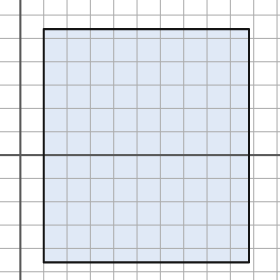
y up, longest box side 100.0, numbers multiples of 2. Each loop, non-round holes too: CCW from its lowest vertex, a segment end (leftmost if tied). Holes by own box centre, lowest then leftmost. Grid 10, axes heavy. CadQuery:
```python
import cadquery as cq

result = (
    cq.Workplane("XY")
    .moveTo(10.0, -46.0)
    .lineTo(98.0, -46.0)
    .lineTo(98.0, 54.0)
    .lineTo(10.0, 54.0)
    .close()
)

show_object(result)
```